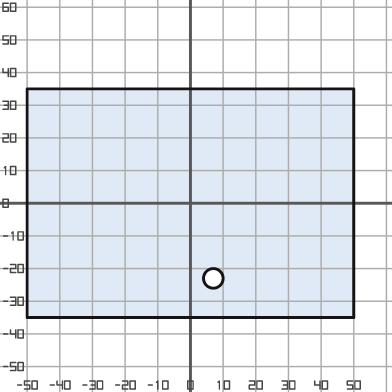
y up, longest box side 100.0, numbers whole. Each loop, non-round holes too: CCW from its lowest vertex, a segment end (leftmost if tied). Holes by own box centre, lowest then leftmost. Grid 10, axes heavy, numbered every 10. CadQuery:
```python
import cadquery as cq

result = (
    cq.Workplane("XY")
    .moveTo(-50.0, -35.0)
    .lineTo(50.0, -35.0)
    .lineTo(50.0, 35.0)
    .lineTo(-50.0, 35.0)
    .close()
    .moveTo(7.0, -23.0)
    .circle(3.0)
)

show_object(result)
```